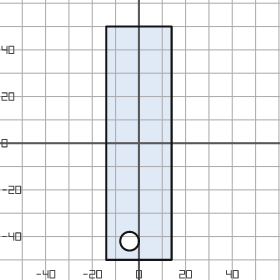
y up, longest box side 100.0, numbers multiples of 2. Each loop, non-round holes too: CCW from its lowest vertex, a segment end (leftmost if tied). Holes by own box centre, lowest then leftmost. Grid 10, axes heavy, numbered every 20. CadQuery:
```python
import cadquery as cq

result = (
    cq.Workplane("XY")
    .moveTo(-14.0, -50.0)
    .lineTo(14.0, -50.0)
    .lineTo(14.0, 50.0)
    .lineTo(-14.0, 50.0)
    .close()
    .moveTo(-4.0, -42.0)
    .circle(4.0)
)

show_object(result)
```